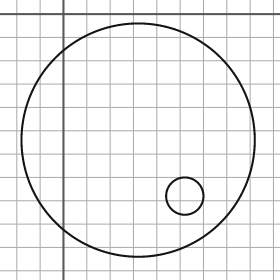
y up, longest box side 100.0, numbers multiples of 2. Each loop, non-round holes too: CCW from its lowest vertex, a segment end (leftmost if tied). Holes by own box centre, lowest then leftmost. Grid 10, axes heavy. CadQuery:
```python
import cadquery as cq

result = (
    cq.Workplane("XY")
    .moveTo(32.0, -54.0)
    .circle(50.0)
    .moveTo(52.0, -78.0)
    .circle(8.0)
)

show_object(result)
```